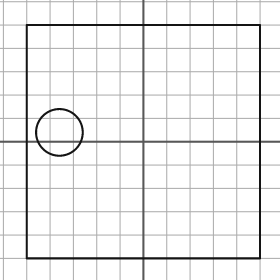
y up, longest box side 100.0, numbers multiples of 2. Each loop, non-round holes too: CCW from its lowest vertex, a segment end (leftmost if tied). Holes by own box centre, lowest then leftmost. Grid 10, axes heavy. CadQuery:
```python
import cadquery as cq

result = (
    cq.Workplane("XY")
    .moveTo(-50.0, -50.0)
    .lineTo(50.0, -50.0)
    .lineTo(50.0, 50.0)
    .lineTo(-50.0, 50.0)
    .close()
    .moveTo(-36.0, 4.0)
    .circle(10.0)
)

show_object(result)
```